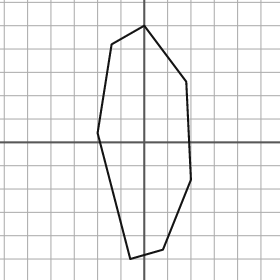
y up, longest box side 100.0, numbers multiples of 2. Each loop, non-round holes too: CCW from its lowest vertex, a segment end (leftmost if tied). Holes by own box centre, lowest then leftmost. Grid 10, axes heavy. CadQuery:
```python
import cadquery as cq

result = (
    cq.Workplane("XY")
    .moveTo(-6.0, -50.0)
    .lineTo(8.0, -46.0)
    .lineTo(20.0, -16.0)
    .lineTo(18.0, 26.0)
    .lineTo(0.0, 50.0)
    .lineTo(-14.0, 42.0)
    .lineTo(-20.0, 4.0)
    .close()
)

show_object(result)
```